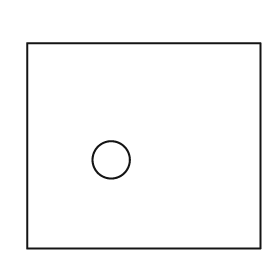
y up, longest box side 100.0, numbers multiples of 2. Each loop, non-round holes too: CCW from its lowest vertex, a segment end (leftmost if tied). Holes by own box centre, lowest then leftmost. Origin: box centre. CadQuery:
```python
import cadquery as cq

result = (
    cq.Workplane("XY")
    .moveTo(-50.0, -44.0)
    .lineTo(50.0, -44.0)
    .lineTo(50.0, 44.0)
    .lineTo(-50.0, 44.0)
    .close()
    .moveTo(-14.0, -6.0)
    .circle(8.0)
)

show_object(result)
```